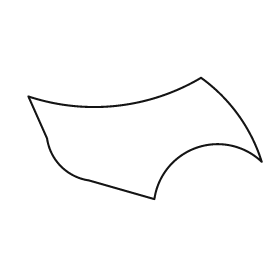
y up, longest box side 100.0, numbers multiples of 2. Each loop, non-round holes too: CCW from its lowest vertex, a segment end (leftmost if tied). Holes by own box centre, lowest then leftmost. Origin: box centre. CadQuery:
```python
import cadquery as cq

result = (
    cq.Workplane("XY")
    .moveTo(4.0, -26.0)
    .threePointArc((22.0, -4.0), (50.0, -10.0))
    .threePointArc((40.0, 10.0), (24.0, 26.0))
    .threePointArc((-12.0, 14.0), (-50.0, 18.0))
    .lineTo(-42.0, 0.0)
    .threePointArc((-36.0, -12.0), (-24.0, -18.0))
    .close()
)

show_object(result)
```